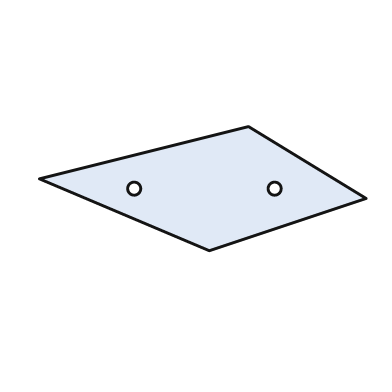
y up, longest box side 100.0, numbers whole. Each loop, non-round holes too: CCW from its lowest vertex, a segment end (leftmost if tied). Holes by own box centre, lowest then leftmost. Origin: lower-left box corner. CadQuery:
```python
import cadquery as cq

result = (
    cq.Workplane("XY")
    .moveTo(52.0, 0.0)
    .lineTo(100.0, 16.0)
    .lineTo(64.0, 38.0)
    .lineTo(0.0, 22.0)
    .close()
    .moveTo(29.0, 19.0)
    .circle(2.0)
    .moveTo(72.0, 19.0)
    .circle(2.0)
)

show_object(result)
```